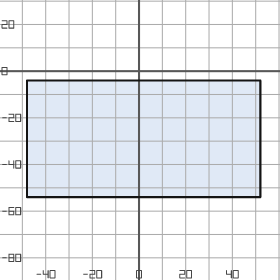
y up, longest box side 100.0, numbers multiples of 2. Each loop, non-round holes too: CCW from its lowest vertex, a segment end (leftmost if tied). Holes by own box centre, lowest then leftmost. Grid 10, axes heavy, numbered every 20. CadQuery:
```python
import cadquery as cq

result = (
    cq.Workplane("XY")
    .moveTo(-48.0, -54.0)
    .lineTo(52.0, -54.0)
    .lineTo(52.0, -4.0)
    .lineTo(-48.0, -4.0)
    .close()
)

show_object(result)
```